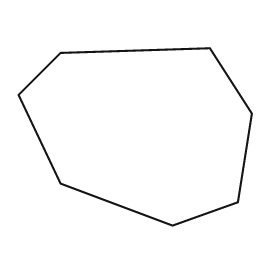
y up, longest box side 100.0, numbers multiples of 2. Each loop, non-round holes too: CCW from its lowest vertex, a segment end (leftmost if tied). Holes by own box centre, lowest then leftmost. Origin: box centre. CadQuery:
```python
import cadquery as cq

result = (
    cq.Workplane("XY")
    .moveTo(16.0, -38.0)
    .lineTo(44.0, -28.0)
    .lineTo(50.0, 10.0)
    .lineTo(32.0, 38.0)
    .lineTo(-32.0, 36.0)
    .lineTo(-50.0, 18.0)
    .lineTo(-32.0, -20.0)
    .close()
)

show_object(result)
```